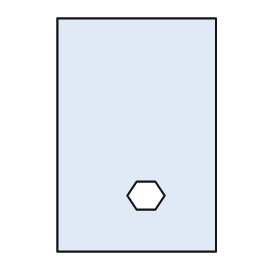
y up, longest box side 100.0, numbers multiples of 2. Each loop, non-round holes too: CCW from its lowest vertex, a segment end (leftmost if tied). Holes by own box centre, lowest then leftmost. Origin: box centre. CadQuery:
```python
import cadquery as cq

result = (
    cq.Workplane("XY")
    .moveTo(-34.0, -50.0)
    .lineTo(34.0, -50.0)
    .lineTo(34.0, 50.0)
    .lineTo(-34.0, 50.0)
    .close()
    .moveTo(0.0, -32.0)
    .lineTo(8.0, -32.0)
    .lineTo(12.0, -26.0)
    .lineTo(8.0, -20.0)
    .lineTo(0.0, -20.0)
    .lineTo(-4.0, -26.0)
    .close()
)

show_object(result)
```